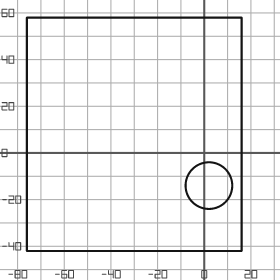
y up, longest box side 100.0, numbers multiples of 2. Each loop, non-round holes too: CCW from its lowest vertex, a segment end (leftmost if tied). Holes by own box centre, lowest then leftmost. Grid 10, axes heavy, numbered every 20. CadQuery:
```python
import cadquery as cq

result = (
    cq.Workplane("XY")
    .moveTo(-76.0, -42.0)
    .lineTo(16.0, -42.0)
    .lineTo(16.0, 58.0)
    .lineTo(-76.0, 58.0)
    .close()
    .moveTo(2.0, -14.0)
    .circle(10.0)
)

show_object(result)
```